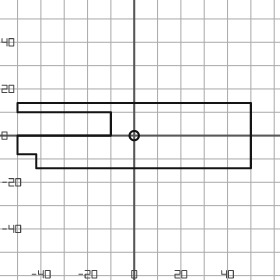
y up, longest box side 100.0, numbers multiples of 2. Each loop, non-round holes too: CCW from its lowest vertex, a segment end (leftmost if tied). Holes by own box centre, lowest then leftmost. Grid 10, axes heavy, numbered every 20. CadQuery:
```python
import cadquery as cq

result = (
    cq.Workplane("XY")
    .moveTo(-42.0, -14.0)
    .lineTo(50.0, -14.0)
    .lineTo(50.0, 14.0)
    .lineTo(-50.0, 14.0)
    .lineTo(-50.0, 10.0)
    .lineTo(-10.0, 10.0)
    .lineTo(-10.0, 0.0)
    .lineTo(-50.0, 0.0)
    .lineTo(-50.0, -8.0)
    .lineTo(-42.0, -8.0)
    .close()
    .moveTo(0.0, 0.0)
    .circle(2.0)
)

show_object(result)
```